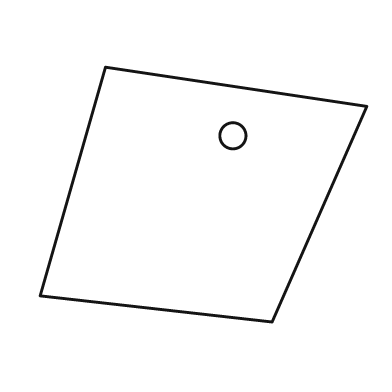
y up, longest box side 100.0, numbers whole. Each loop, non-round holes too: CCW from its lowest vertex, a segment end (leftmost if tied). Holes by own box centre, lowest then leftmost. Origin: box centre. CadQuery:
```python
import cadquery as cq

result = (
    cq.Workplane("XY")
    .moveTo(21.0, -39.0)
    .lineTo(50.0, 27.0)
    .lineTo(-30.0, 39.0)
    .lineTo(-50.0, -31.0)
    .close()
    .moveTo(9.0, 18.0)
    .circle(4.0)
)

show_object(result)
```